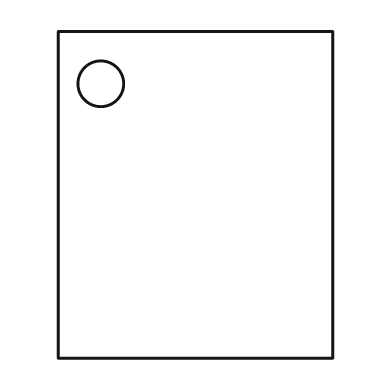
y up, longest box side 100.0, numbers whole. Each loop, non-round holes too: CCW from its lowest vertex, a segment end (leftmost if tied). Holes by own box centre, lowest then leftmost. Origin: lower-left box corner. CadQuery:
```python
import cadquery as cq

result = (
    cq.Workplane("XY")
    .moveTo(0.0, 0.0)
    .lineTo(84.0, 0.0)
    .lineTo(84.0, 100.0)
    .lineTo(0.0, 100.0)
    .close()
    .moveTo(13.0, 84.0)
    .circle(7.0)
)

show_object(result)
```